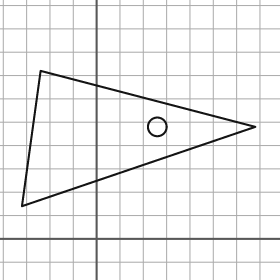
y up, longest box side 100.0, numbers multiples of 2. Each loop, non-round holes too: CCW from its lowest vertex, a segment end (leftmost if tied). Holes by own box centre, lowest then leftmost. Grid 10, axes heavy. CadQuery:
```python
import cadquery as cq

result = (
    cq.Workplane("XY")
    .moveTo(-32.0, 14.0)
    .lineTo(68.0, 48.0)
    .lineTo(-24.0, 72.0)
    .close()
    .moveTo(26.0, 48.0)
    .circle(4.0)
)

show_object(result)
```